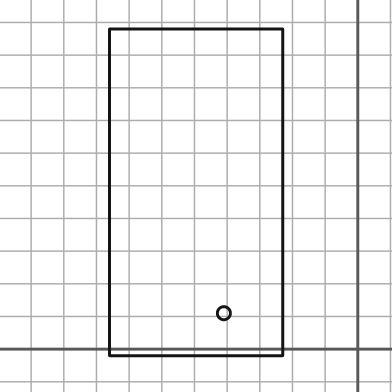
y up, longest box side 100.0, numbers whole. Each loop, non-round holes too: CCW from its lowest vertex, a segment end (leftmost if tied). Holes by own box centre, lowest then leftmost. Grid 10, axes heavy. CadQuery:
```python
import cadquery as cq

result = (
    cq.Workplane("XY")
    .moveTo(-76.0, -2.0)
    .lineTo(-23.0, -2.0)
    .lineTo(-23.0, 98.0)
    .lineTo(-76.0, 98.0)
    .close()
    .moveTo(-41.0, 11.0)
    .circle(2.0)
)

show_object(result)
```